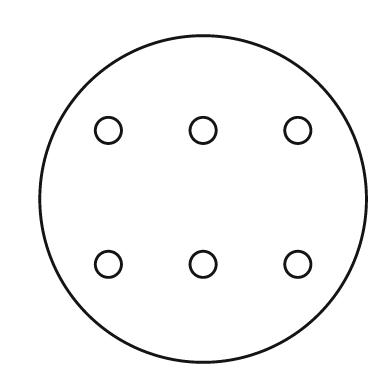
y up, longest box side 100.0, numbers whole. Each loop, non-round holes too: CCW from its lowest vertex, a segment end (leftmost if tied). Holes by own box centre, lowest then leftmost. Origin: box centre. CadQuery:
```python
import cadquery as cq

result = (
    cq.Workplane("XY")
    .moveTo(0.0, 0.0)
    .circle(50.0)
    .moveTo(-29.0, -20.0)
    .circle(4.0)
    .moveTo(0.0, -20.0)
    .circle(4.0)
    .moveTo(29.0, -20.0)
    .circle(4.0)
    .moveTo(-29.0, 21.0)
    .circle(4.0)
    .moveTo(0.0, 21.0)
    .circle(4.0)
    .moveTo(29.0, 21.0)
    .circle(4.0)
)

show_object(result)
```